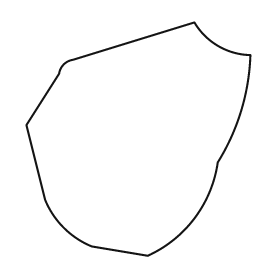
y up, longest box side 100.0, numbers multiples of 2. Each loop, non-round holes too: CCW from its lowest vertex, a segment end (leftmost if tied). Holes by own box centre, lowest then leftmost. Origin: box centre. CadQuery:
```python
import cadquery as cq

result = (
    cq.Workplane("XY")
    .moveTo(4.0, -50.0)
    .threePointArc((24.0, -34.0), (34.0, -10.0))
    .threePointArc((44.0, 12.0), (48.0, 36.0))
    .threePointArc((34.0, 40.0), (24.0, 50.0))
    .lineTo(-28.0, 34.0)
    .threePointArc((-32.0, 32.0), (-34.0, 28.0))
    .lineTo(-48.0, 6.0)
    .lineTo(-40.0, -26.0)
    .threePointArc((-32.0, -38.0), (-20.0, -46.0))
    .close()
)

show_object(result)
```